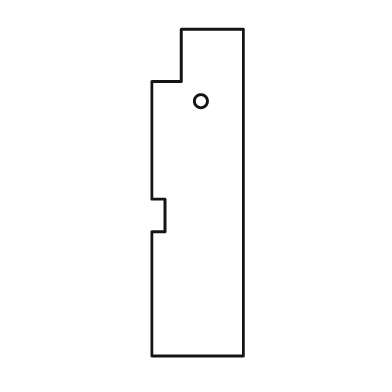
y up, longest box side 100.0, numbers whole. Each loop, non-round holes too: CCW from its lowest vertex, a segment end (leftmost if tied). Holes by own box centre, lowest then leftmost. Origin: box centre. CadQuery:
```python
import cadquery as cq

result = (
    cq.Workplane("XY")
    .moveTo(-14.0, -50.0)
    .lineTo(14.0, -50.0)
    .lineTo(14.0, 50.0)
    .lineTo(-5.0, 50.0)
    .lineTo(-5.0, 34.0)
    .lineTo(-14.0, 34.0)
    .lineTo(-14.0, -2.0)
    .lineTo(-10.0, -2.0)
    .lineTo(-10.0, -12.0)
    .lineTo(-14.0, -12.0)
    .close()
    .moveTo(1.0, 28.0)
    .circle(2.0)
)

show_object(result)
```